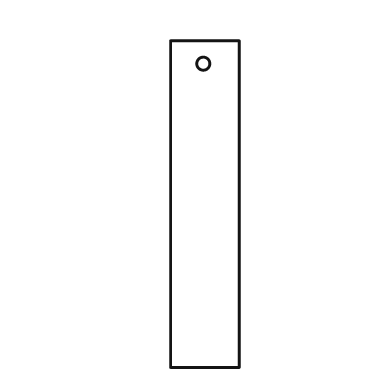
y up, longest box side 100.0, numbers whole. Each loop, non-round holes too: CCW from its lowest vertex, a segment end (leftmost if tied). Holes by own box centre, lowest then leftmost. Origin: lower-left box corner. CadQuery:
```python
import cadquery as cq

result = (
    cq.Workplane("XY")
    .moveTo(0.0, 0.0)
    .lineTo(21.0, 0.0)
    .lineTo(21.0, 100.0)
    .lineTo(0.0, 100.0)
    .close()
    .moveTo(10.0, 93.0)
    .circle(2.0)
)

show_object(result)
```